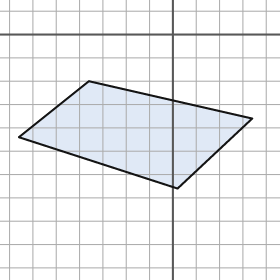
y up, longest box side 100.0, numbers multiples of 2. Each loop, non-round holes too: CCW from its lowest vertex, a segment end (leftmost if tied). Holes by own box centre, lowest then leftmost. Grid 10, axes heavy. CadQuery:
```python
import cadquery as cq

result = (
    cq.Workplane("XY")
    .moveTo(2.0, -66.0)
    .lineTo(34.0, -36.0)
    .lineTo(-36.0, -20.0)
    .lineTo(-66.0, -44.0)
    .close()
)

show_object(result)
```